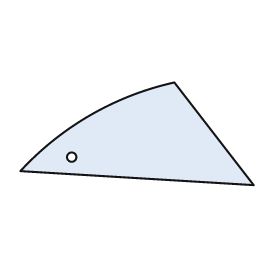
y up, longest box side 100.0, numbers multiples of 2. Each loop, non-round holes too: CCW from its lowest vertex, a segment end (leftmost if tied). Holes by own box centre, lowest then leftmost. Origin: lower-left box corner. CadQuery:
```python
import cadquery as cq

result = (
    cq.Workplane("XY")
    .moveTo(100.0, 0.0)
    .lineTo(66.0, 44.0)
    .threePointArc((30.0, 30.0), (0.0, 6.0))
    .close()
    .moveTo(22.0, 12.0)
    .circle(2.0)
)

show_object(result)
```